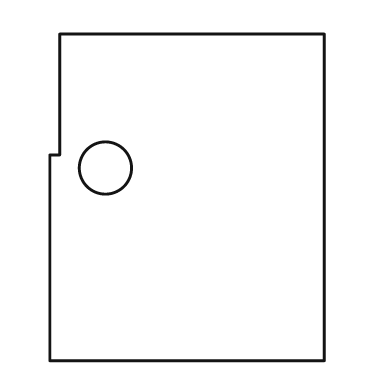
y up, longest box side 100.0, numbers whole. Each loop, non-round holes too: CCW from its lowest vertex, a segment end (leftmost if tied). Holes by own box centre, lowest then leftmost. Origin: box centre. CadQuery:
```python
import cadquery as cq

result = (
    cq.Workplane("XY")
    .moveTo(-42.0, -50.0)
    .lineTo(42.0, -50.0)
    .lineTo(42.0, 50.0)
    .lineTo(-39.0, 50.0)
    .lineTo(-39.0, 13.0)
    .lineTo(-42.0, 13.0)
    .close()
    .moveTo(-25.0, 9.0)
    .circle(8.0)
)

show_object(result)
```